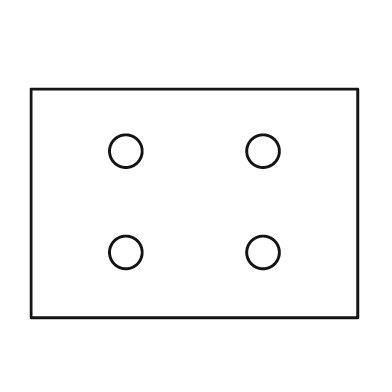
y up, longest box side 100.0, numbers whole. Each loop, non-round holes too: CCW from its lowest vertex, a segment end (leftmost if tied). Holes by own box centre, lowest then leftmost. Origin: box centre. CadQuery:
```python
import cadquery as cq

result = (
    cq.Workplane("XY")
    .moveTo(-50.0, -35.0)
    .lineTo(50.0, -35.0)
    .lineTo(50.0, 35.0)
    .lineTo(-50.0, 35.0)
    .close()
    .moveTo(-21.0, -15.0)
    .circle(5.0)
    .moveTo(21.0, -15.0)
    .circle(5.0)
    .moveTo(-21.0, 16.0)
    .circle(5.0)
    .moveTo(21.0, 16.0)
    .circle(5.0)
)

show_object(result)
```